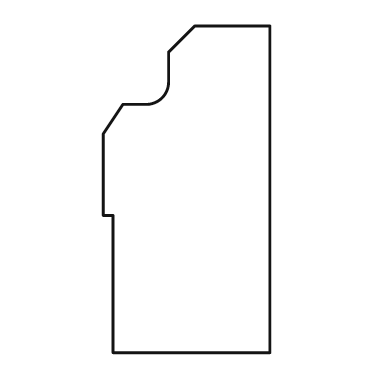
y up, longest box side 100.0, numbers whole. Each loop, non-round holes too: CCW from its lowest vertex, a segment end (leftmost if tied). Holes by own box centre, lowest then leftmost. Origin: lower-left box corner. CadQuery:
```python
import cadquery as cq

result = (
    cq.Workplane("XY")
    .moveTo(3.0, 0.0)
    .lineTo(51.0, 0.0)
    .lineTo(51.0, 100.0)
    .lineTo(28.0, 100.0)
    .lineTo(20.0, 92.0)
    .lineTo(20.0, 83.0)
    .threePointArc((18.0, 78.0), (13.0, 76.0))
    .lineTo(6.0, 76.0)
    .lineTo(0.0, 67.0)
    .lineTo(0.0, 42.0)
    .lineTo(3.0, 42.0)
    .close()
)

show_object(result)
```